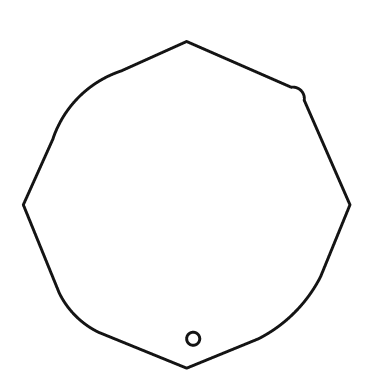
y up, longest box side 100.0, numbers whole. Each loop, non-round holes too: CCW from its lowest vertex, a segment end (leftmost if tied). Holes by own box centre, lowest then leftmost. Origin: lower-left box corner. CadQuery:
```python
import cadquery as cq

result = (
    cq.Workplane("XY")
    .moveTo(50.0, 0.0)
    .lineTo(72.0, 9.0)
    .threePointArc((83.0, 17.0), (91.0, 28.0))
    .lineTo(100.0, 50.0)
    .lineTo(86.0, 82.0)
    .threePointArc((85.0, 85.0), (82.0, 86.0))
    .lineTo(50.0, 100.0)
    .lineTo(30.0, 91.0)
    .threePointArc((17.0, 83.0), (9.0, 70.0))
    .lineTo(0.0, 50.0)
    .lineTo(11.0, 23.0)
    .threePointArc((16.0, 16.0), (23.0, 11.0))
    .close()
    .moveTo(52.0, 9.0)
    .circle(2.0)
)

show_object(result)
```